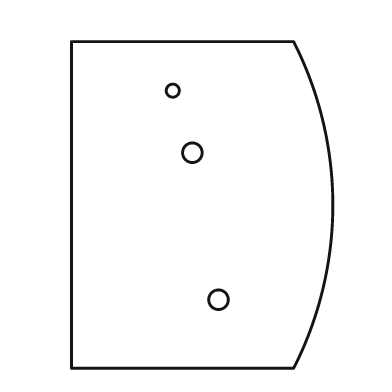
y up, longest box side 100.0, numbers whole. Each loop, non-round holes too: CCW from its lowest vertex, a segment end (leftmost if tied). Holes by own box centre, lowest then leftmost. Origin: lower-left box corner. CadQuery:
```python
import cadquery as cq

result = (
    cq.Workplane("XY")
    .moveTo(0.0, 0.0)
    .lineTo(68.0, 0.0)
    .threePointArc((80.0, 50.0), (68.0, 100.0))
    .lineTo(0.0, 100.0)
    .close()
    .moveTo(45.0, 21.0)
    .circle(3.0)
    .moveTo(37.0, 66.0)
    .circle(3.0)
    .moveTo(31.0, 85.0)
    .circle(2.0)
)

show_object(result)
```